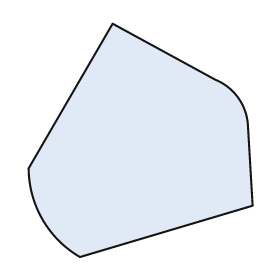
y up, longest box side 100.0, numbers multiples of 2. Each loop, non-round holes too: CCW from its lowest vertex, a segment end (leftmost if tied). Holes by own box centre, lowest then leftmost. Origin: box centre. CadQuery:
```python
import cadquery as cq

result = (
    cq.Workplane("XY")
    .moveTo(-26.0, -50.0)
    .lineTo(48.0, -28.0)
    .lineTo(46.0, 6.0)
    .threePointArc((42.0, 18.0), (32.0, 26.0))
    .lineTo(-12.0, 50.0)
    .lineTo(-48.0, -12.0)
    .threePointArc((-42.0, -34.0), (-26.0, -50.0))
    .close()
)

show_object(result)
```